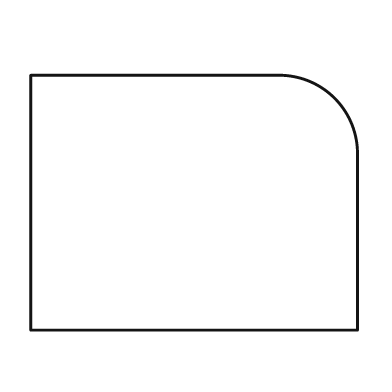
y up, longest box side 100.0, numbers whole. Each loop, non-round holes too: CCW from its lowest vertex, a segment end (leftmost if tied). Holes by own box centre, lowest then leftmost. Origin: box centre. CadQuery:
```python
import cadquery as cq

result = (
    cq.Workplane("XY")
    .moveTo(-50.0, -39.0)
    .lineTo(50.0, -39.0)
    .lineTo(50.0, 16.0)
    .threePointArc((43.0, 32.0), (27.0, 39.0))
    .lineTo(-50.0, 39.0)
    .close()
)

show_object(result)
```